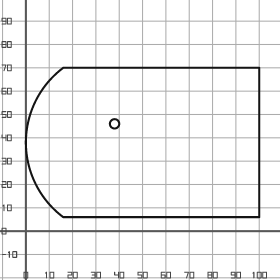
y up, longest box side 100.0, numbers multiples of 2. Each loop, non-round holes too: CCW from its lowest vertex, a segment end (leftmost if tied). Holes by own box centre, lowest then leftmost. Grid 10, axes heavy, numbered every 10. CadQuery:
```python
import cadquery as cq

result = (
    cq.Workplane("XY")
    .moveTo(16.0, 6.0)
    .lineTo(100.0, 6.0)
    .lineTo(100.0, 70.0)
    .lineTo(16.0, 70.0)
    .threePointArc((0.0, 38.0), (16.0, 6.0))
    .close()
    .moveTo(38.0, 46.0)
    .circle(2.0)
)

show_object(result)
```